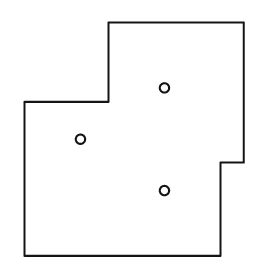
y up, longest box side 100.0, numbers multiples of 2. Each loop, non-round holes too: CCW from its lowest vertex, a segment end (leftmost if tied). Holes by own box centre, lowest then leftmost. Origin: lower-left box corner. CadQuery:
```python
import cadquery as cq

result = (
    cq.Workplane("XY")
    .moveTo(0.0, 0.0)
    .lineTo(84.0, 0.0)
    .lineTo(84.0, 40.0)
    .lineTo(94.0, 40.0)
    .lineTo(94.0, 100.0)
    .lineTo(36.0, 100.0)
    .lineTo(36.0, 66.0)
    .lineTo(0.0, 66.0)
    .close()
    .moveTo(60.0, 28.0)
    .circle(2.0)
    .moveTo(24.0, 50.0)
    .circle(2.0)
    .moveTo(60.0, 72.0)
    .circle(2.0)
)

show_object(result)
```